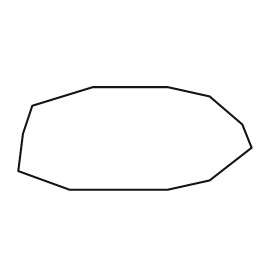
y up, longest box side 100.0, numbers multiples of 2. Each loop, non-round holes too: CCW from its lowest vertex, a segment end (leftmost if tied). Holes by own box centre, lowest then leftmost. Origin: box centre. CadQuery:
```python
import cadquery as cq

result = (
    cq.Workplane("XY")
    .moveTo(-28.0, -22.0)
    .lineTo(14.0, -22.0)
    .lineTo(32.0, -18.0)
    .lineTo(50.0, -4.0)
    .lineTo(46.0, 6.0)
    .lineTo(32.0, 18.0)
    .lineTo(14.0, 22.0)
    .lineTo(-18.0, 22.0)
    .lineTo(-44.0, 14.0)
    .lineTo(-48.0, 2.0)
    .lineTo(-50.0, -14.0)
    .close()
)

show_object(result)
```